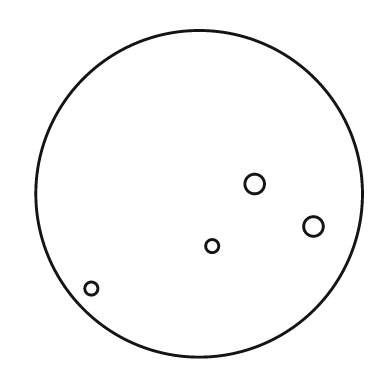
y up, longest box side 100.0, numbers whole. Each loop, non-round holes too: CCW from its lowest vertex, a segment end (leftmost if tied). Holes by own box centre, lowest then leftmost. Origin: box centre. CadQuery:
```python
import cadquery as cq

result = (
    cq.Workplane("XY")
    .moveTo(0.0, 0.0)
    .circle(50.0)
    .moveTo(-33.0, -29.0)
    .circle(2.0)
    .moveTo(4.0, -16.0)
    .circle(2.0)
    .moveTo(35.0, -10.0)
    .circle(3.0)
    .moveTo(17.0, 3.0)
    .circle(3.0)
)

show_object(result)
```